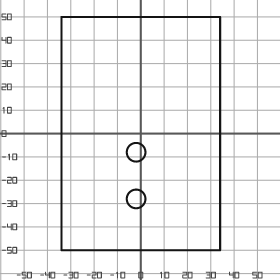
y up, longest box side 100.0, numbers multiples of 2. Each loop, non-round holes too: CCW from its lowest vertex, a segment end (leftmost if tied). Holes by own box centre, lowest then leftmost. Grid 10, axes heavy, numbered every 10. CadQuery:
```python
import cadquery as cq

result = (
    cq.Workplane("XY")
    .moveTo(-34.0, -50.0)
    .lineTo(34.0, -50.0)
    .lineTo(34.0, 50.0)
    .lineTo(-34.0, 50.0)
    .close()
    .moveTo(-2.0, -28.0)
    .circle(4.0)
    .moveTo(-2.0, -8.0)
    .circle(4.0)
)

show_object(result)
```